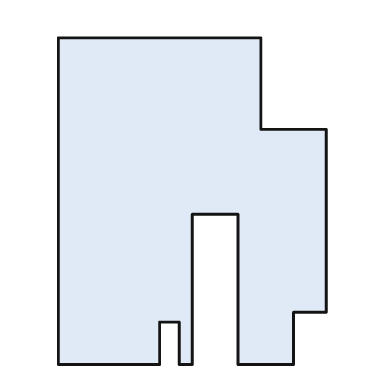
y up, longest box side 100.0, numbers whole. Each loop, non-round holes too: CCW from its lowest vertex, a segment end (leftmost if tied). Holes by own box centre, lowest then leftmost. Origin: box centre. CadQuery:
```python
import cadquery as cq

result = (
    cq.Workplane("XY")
    .moveTo(-41.0, -50.0)
    .lineTo(-10.0, -50.0)
    .lineTo(-10.0, -37.0)
    .lineTo(-4.0, -37.0)
    .lineTo(-4.0, -50.0)
    .lineTo(0.0, -50.0)
    .lineTo(0.0, -4.0)
    .lineTo(14.0, -4.0)
    .lineTo(14.0, -50.0)
    .lineTo(31.0, -50.0)
    .lineTo(31.0, -34.0)
    .lineTo(41.0, -34.0)
    .lineTo(41.0, 22.0)
    .lineTo(21.0, 22.0)
    .lineTo(21.0, 50.0)
    .lineTo(-41.0, 50.0)
    .close()
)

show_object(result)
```